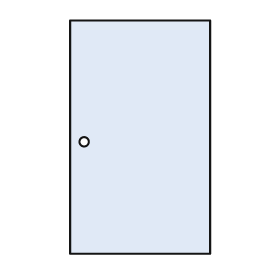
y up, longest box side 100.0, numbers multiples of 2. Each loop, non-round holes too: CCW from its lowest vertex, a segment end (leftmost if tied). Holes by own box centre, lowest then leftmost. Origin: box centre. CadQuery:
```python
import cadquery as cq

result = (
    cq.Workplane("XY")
    .moveTo(-30.0, -50.0)
    .lineTo(30.0, -50.0)
    .lineTo(30.0, 50.0)
    .lineTo(-30.0, 50.0)
    .close()
    .moveTo(-24.0, -2.0)
    .circle(2.0)
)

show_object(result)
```